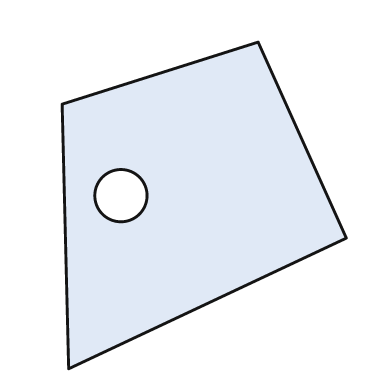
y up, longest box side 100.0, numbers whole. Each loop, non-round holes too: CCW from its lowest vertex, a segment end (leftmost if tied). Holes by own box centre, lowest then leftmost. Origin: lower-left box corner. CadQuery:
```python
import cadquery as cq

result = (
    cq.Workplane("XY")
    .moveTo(2.0, 0.0)
    .lineTo(87.0, 40.0)
    .lineTo(60.0, 100.0)
    .lineTo(0.0, 81.0)
    .close()
    .moveTo(18.0, 53.0)
    .circle(8.0)
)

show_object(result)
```